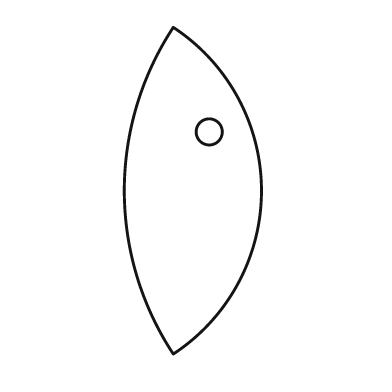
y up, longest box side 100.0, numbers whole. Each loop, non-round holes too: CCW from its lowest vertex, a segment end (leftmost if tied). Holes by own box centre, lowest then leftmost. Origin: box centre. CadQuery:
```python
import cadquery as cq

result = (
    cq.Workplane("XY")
    .moveTo(-6.0, -50.0)
    .threePointArc((21.0, 0.0), (-6.0, 50.0))
    .threePointArc((-21.0, 0.0), (-6.0, -50.0))
    .close()
    .moveTo(5.0, 18.0)
    .circle(4.0)
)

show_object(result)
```